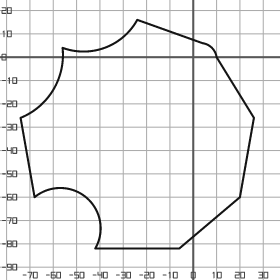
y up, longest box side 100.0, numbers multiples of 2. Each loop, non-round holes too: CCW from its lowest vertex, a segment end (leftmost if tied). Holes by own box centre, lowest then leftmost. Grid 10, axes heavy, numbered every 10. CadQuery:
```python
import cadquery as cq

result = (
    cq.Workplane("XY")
    .moveTo(-42.0, -82.0)
    .lineTo(-6.0, -82.0)
    .lineTo(20.0, -60.0)
    .lineTo(26.0, -26.0)
    .lineTo(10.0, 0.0)
    .threePointArc((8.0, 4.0), (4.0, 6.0))
    .lineTo(-24.0, 16.0)
    .threePointArc((-38.0, 4.0), (-56.0, 4.0))
    .threePointArc((-60.0, -14.0), (-74.0, -26.0))
    .lineTo(-68.0, -60.0)
    .threePointArc((-46.0, -60.0), (-42.0, -82.0))
    .close()
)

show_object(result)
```